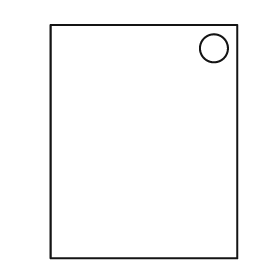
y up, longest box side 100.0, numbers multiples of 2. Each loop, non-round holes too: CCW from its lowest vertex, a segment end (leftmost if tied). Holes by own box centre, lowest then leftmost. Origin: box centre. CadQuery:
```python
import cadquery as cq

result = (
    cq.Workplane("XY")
    .moveTo(-40.0, -50.0)
    .lineTo(40.0, -50.0)
    .lineTo(40.0, 50.0)
    .lineTo(-40.0, 50.0)
    .close()
    .moveTo(30.0, 40.0)
    .circle(6.0)
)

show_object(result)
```